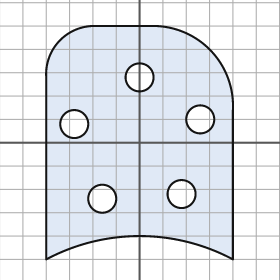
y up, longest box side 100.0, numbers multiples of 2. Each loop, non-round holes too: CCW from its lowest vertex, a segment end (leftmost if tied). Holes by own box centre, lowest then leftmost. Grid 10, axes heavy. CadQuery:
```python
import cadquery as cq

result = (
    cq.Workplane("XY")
    .moveTo(-40.0, -50.0)
    .threePointArc((0.0, -40.0), (40.0, -50.0))
    .lineTo(40.0, 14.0)
    .threePointArc((30.0, 40.0), (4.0, 50.0))
    .lineTo(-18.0, 50.0)
    .threePointArc((-34.0, 44.0), (-40.0, 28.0))
    .close()
    .moveTo(-16.0, -24.0)
    .circle(6.0)
    .moveTo(18.0, -22.0)
    .circle(6.0)
    .moveTo(-28.0, 8.0)
    .circle(6.0)
    .moveTo(26.0, 10.0)
    .circle(6.0)
    .moveTo(0.0, 28.0)
    .circle(6.0)
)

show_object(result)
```